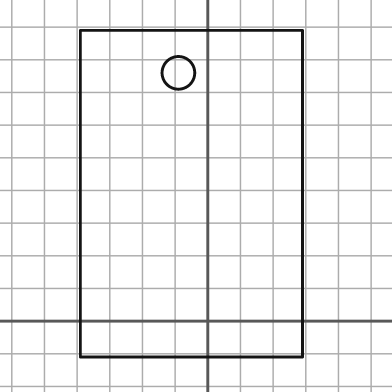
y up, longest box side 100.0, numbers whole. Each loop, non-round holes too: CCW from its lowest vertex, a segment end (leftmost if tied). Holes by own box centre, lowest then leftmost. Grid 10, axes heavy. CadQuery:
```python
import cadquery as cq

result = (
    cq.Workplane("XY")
    .moveTo(-39.0, -11.0)
    .lineTo(29.0, -11.0)
    .lineTo(29.0, 89.0)
    .lineTo(-39.0, 89.0)
    .close()
    .moveTo(-9.0, 76.0)
    .circle(5.0)
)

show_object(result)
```